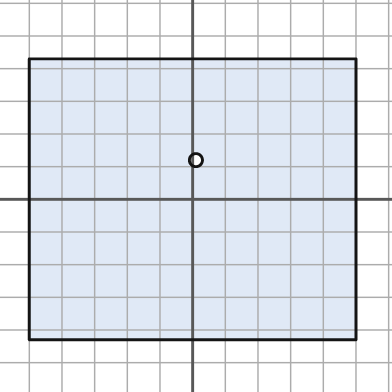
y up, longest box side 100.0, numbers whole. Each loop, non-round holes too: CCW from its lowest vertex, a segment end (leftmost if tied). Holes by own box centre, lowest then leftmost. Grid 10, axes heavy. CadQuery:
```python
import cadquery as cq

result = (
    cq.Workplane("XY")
    .moveTo(-50.0, -43.0)
    .lineTo(50.0, -43.0)
    .lineTo(50.0, 43.0)
    .lineTo(-50.0, 43.0)
    .close()
    .moveTo(1.0, 12.0)
    .circle(2.0)
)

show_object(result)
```